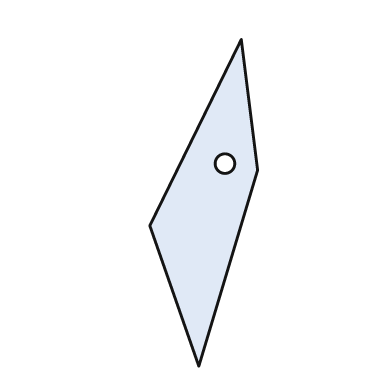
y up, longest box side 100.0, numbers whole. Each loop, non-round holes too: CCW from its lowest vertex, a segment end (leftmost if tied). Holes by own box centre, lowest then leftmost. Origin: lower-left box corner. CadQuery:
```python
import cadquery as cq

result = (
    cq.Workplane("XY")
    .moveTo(15.0, 0.0)
    .lineTo(33.0, 60.0)
    .lineTo(28.0, 100.0)
    .lineTo(0.0, 43.0)
    .close()
    .moveTo(23.0, 62.0)
    .circle(3.0)
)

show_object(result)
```